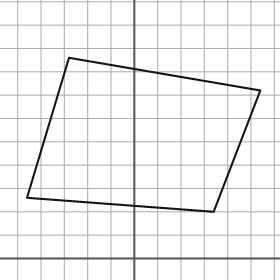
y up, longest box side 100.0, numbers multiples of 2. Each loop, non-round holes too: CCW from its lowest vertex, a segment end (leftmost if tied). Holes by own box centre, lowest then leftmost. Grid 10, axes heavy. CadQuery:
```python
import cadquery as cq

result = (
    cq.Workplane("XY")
    .moveTo(34.0, 20.0)
    .lineTo(54.0, 72.0)
    .lineTo(-28.0, 86.0)
    .lineTo(-46.0, 26.0)
    .close()
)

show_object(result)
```